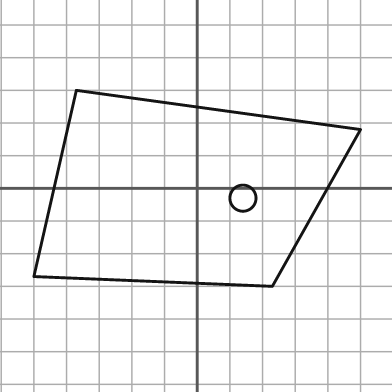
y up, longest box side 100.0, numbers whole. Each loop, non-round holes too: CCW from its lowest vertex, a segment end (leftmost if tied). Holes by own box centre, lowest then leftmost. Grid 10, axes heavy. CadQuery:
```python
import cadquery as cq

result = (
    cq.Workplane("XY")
    .moveTo(23.0, -30.0)
    .lineTo(50.0, 18.0)
    .lineTo(-37.0, 30.0)
    .lineTo(-50.0, -27.0)
    .close()
    .moveTo(14.0, -3.0)
    .circle(4.0)
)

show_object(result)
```